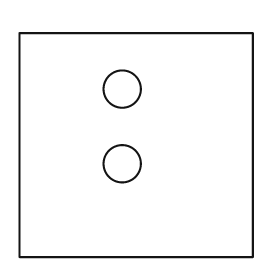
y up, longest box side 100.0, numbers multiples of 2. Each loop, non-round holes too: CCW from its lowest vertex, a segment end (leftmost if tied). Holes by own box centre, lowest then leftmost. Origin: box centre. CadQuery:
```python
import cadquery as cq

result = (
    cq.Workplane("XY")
    .moveTo(-50.0, -48.0)
    .lineTo(50.0, -48.0)
    .lineTo(50.0, 48.0)
    .lineTo(-50.0, 48.0)
    .close()
    .moveTo(-6.0, -8.0)
    .circle(8.0)
    .moveTo(-6.0, 24.0)
    .circle(8.0)
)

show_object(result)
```